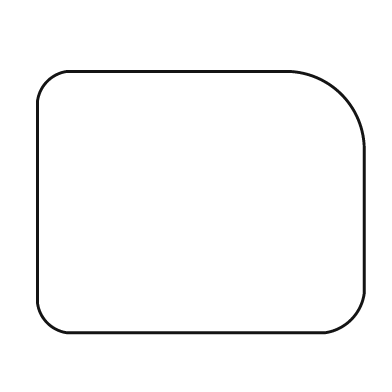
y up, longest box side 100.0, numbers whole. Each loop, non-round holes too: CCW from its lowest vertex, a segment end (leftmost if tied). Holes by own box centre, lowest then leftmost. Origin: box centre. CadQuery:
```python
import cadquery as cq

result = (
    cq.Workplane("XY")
    .moveTo(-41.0, -40.0)
    .lineTo(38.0, -40.0)
    .threePointArc((46.0, -36.0), (50.0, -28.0))
    .lineTo(50.0, 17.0)
    .threePointArc((43.0, 33.0), (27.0, 40.0))
    .lineTo(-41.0, 40.0)
    .threePointArc((-47.0, 37.0), (-50.0, 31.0))
    .lineTo(-50.0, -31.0)
    .threePointArc((-47.0, -37.0), (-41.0, -40.0))
    .close()
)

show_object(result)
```